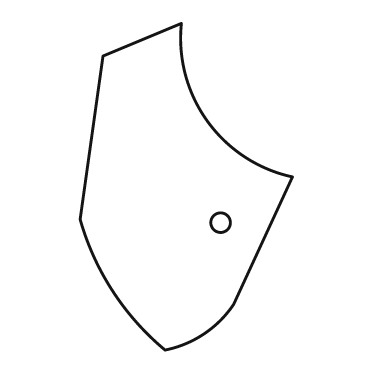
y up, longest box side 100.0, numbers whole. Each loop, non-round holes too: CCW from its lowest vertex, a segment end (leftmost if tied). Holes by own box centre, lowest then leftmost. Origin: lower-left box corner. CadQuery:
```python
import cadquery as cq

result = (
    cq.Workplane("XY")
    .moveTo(26.0, 0.0)
    .threePointArc((38.0, 5.0), (47.0, 14.0))
    .lineTo(65.0, 53.0)
    .threePointArc((39.0, 70.0), (31.0, 100.0))
    .lineTo(7.0, 90.0)
    .lineTo(0.0, 40.0)
    .threePointArc((10.0, 18.0), (26.0, 0.0))
    .close()
    .moveTo(43.0, 39.0)
    .circle(3.0)
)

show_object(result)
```